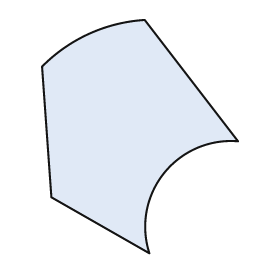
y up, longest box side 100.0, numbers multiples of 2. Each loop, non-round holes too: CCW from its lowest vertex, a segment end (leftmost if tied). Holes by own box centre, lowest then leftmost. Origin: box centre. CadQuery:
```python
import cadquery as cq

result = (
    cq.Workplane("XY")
    .moveTo(4.0, -50.0)
    .threePointArc((10.0, -16.0), (42.0, -2.0))
    .lineTo(2.0, 50.0)
    .threePointArc((-22.0, 44.0), (-42.0, 30.0))
    .lineTo(-38.0, -26.0)
    .close()
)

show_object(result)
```